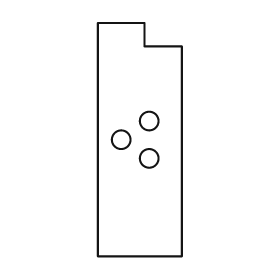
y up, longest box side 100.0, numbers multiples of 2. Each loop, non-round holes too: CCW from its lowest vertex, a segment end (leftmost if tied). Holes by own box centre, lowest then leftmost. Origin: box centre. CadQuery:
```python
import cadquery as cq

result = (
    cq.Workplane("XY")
    .moveTo(-18.0, -50.0)
    .lineTo(18.0, -50.0)
    .lineTo(18.0, 40.0)
    .lineTo(2.0, 40.0)
    .lineTo(2.0, 50.0)
    .lineTo(-18.0, 50.0)
    .close()
    .moveTo(4.0, -8.0)
    .circle(4.0)
    .moveTo(-8.0, 0.0)
    .circle(4.0)
    .moveTo(4.0, 8.0)
    .circle(4.0)
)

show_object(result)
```